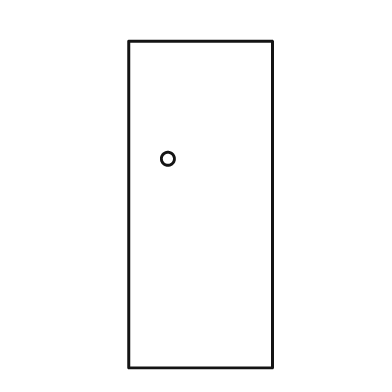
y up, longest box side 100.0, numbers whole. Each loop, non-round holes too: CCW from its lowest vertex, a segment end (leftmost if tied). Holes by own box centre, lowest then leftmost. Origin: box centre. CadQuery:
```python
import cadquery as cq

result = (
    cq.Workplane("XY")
    .moveTo(-22.0, -50.0)
    .lineTo(22.0, -50.0)
    .lineTo(22.0, 50.0)
    .lineTo(-22.0, 50.0)
    .close()
    .moveTo(-10.0, 14.0)
    .circle(2.0)
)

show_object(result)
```